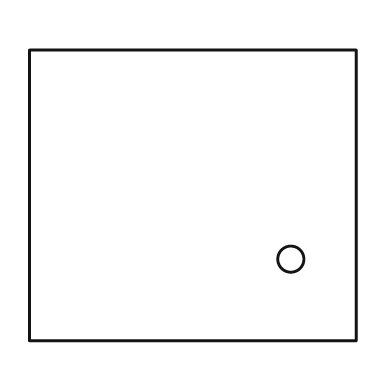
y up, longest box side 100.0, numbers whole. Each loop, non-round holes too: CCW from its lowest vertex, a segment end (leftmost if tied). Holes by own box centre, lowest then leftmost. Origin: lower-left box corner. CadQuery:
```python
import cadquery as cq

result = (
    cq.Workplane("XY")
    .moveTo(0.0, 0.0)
    .lineTo(100.0, 0.0)
    .lineTo(100.0, 89.0)
    .lineTo(0.0, 89.0)
    .close()
    .moveTo(80.0, 25.0)
    .circle(4.0)
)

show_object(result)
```